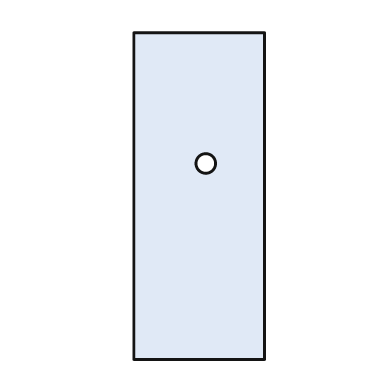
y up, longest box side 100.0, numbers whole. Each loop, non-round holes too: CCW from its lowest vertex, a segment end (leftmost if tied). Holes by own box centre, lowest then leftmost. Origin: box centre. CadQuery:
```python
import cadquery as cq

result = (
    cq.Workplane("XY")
    .moveTo(-20.0, -50.0)
    .lineTo(20.0, -50.0)
    .lineTo(20.0, 50.0)
    .lineTo(-20.0, 50.0)
    .close()
    .moveTo(2.0, 10.0)
    .circle(3.0)
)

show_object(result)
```